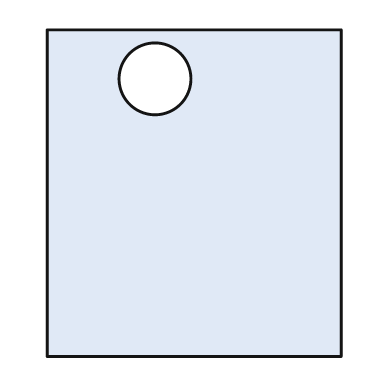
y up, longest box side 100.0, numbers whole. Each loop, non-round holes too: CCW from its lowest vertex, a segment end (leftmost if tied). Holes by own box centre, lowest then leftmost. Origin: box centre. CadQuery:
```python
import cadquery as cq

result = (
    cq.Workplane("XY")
    .moveTo(-45.0, -50.0)
    .lineTo(45.0, -50.0)
    .lineTo(45.0, 50.0)
    .lineTo(-45.0, 50.0)
    .close()
    .moveTo(-12.0, 35.0)
    .circle(11.0)
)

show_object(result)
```